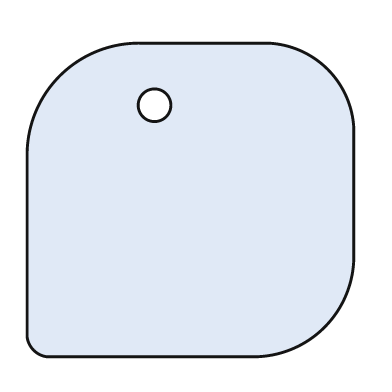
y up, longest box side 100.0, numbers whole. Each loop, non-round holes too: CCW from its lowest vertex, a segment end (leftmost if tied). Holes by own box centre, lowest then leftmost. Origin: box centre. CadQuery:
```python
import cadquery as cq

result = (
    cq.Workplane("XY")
    .moveTo(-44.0, -48.0)
    .lineTo(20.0, -48.0)
    .threePointArc((41.0, -39.0), (50.0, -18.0))
    .lineTo(50.0, 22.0)
    .threePointArc((42.0, 40.0), (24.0, 48.0))
    .lineTo(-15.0, 48.0)
    .threePointArc((-40.0, 38.0), (-50.0, 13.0))
    .lineTo(-50.0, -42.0)
    .threePointArc((-48.0, -46.0), (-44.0, -48.0))
    .close()
    .moveTo(-11.0, 29.0)
    .circle(5.0)
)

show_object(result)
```